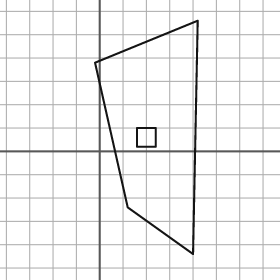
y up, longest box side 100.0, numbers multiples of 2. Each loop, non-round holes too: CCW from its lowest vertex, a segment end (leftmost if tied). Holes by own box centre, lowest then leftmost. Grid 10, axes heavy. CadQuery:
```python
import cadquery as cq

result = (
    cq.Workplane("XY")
    .moveTo(40.0, -44.0)
    .lineTo(42.0, 56.0)
    .lineTo(-2.0, 38.0)
    .lineTo(12.0, -24.0)
    .close()
    .moveTo(16.0, 2.0)
    .lineTo(24.0, 2.0)
    .lineTo(24.0, 10.0)
    .lineTo(16.0, 10.0)
    .close()
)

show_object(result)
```